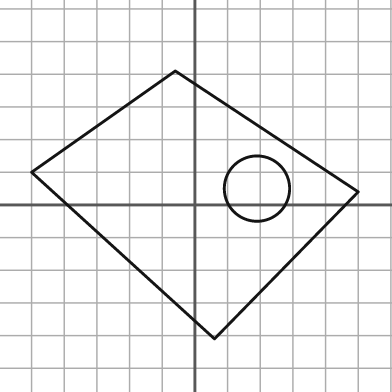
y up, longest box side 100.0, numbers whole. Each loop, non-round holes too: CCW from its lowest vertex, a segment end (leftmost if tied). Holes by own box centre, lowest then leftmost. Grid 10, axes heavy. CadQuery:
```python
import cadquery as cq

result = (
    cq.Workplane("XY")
    .moveTo(6.0, -41.0)
    .lineTo(50.0, 4.0)
    .lineTo(-6.0, 41.0)
    .lineTo(-50.0, 10.0)
    .close()
    .moveTo(19.0, 5.0)
    .circle(10.0)
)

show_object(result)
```